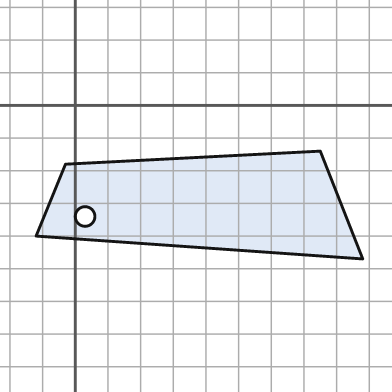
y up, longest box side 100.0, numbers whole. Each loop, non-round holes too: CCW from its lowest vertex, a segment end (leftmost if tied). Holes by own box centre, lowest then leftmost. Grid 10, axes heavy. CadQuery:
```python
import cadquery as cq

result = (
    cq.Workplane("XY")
    .moveTo(88.0, -47.0)
    .lineTo(75.0, -14.0)
    .lineTo(-3.0, -18.0)
    .lineTo(-12.0, -40.0)
    .close()
    .moveTo(3.0, -34.0)
    .circle(3.0)
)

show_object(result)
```